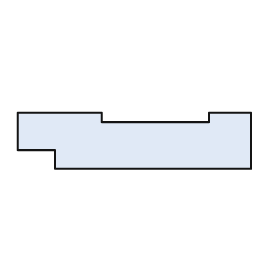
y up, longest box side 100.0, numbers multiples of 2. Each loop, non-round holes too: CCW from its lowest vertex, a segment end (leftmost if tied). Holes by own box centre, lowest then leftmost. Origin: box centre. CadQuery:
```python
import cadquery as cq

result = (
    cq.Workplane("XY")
    .moveTo(-34.0, -12.0)
    .lineTo(50.0, -12.0)
    .lineTo(50.0, 12.0)
    .lineTo(32.0, 12.0)
    .lineTo(32.0, 8.0)
    .lineTo(-14.0, 8.0)
    .lineTo(-14.0, 12.0)
    .lineTo(-50.0, 12.0)
    .lineTo(-50.0, -4.0)
    .lineTo(-34.0, -4.0)
    .close()
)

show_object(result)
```